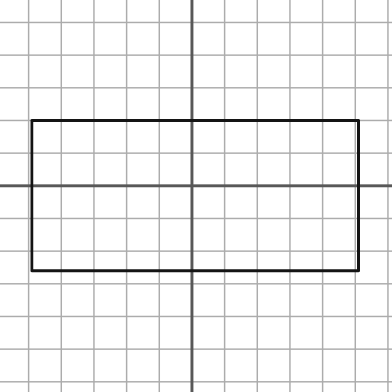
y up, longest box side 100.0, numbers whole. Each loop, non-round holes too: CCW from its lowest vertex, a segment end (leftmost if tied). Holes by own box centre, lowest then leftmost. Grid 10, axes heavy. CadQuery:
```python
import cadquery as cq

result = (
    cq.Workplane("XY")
    .moveTo(-49.0, -26.0)
    .lineTo(51.0, -26.0)
    .lineTo(51.0, 20.0)
    .lineTo(-49.0, 20.0)
    .close()
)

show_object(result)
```